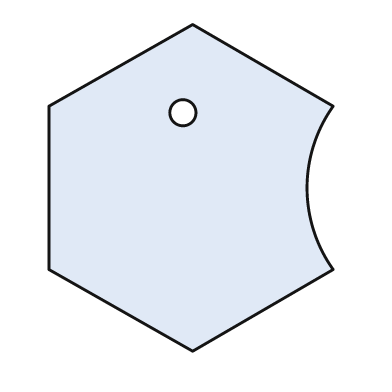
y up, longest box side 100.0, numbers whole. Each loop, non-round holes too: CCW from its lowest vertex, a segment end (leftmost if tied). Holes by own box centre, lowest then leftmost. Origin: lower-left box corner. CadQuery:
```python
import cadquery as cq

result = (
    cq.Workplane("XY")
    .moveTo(44.0, 0.0)
    .lineTo(87.0, 25.0)
    .threePointArc((79.0, 50.0), (87.0, 75.0))
    .lineTo(44.0, 100.0)
    .lineTo(0.0, 75.0)
    .lineTo(0.0, 25.0)
    .close()
    .moveTo(41.0, 73.0)
    .circle(4.0)
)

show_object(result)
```